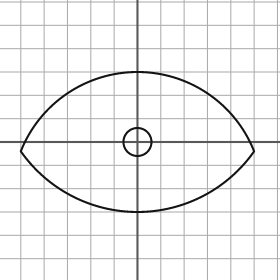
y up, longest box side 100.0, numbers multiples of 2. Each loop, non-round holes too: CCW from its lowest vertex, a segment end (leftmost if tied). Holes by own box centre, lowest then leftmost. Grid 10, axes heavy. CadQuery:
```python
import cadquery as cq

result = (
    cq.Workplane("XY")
    .moveTo(-50.0, -4.0)
    .threePointArc((0.0, -30.0), (50.0, -4.0))
    .threePointArc((0.0, 30.0), (-50.0, -4.0))
    .close()
    .moveTo(0.0, 0.0)
    .circle(6.0)
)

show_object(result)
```